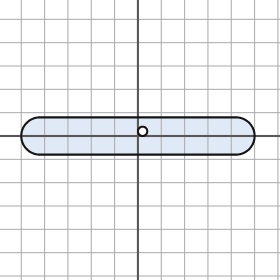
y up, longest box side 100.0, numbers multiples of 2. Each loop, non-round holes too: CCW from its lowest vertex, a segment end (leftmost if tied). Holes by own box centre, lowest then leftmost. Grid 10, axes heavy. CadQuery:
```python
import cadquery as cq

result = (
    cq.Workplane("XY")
    .moveTo(-42.0, -8.0)
    .lineTo(42.0, -8.0)
    .threePointArc((50.0, 0.0), (42.0, 8.0))
    .lineTo(-42.0, 8.0)
    .threePointArc((-50.0, 0.0), (-42.0, -8.0))
    .close()
    .moveTo(2.0, 2.0)
    .circle(2.0)
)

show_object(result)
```